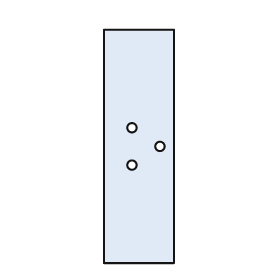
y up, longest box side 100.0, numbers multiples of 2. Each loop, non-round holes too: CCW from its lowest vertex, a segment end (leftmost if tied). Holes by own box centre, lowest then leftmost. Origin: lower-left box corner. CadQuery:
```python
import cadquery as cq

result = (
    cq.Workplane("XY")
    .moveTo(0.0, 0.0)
    .lineTo(30.0, 0.0)
    .lineTo(30.0, 100.0)
    .lineTo(0.0, 100.0)
    .close()
    .moveTo(12.0, 42.0)
    .circle(2.0)
    .moveTo(24.0, 50.0)
    .circle(2.0)
    .moveTo(12.0, 58.0)
    .circle(2.0)
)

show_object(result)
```